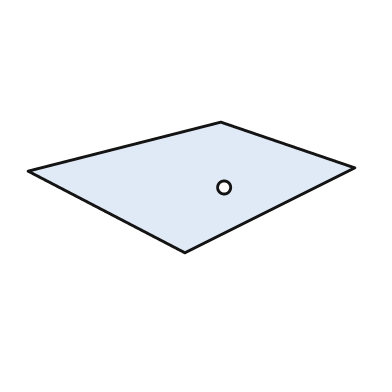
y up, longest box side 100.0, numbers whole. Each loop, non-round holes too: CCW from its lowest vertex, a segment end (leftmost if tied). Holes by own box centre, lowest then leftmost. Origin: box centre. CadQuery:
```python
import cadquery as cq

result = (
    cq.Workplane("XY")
    .moveTo(-2.0, -20.0)
    .lineTo(50.0, 6.0)
    .lineTo(9.0, 20.0)
    .lineTo(-50.0, 5.0)
    .close()
    .moveTo(10.0, 0.0)
    .circle(2.0)
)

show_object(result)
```